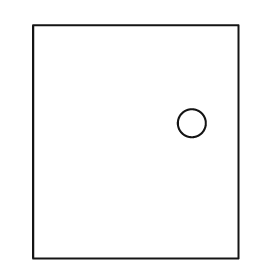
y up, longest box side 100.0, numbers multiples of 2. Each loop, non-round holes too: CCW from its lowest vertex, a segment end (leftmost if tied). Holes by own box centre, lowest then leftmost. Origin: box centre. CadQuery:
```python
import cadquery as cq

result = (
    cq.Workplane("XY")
    .moveTo(-44.0, -50.0)
    .lineTo(44.0, -50.0)
    .lineTo(44.0, 50.0)
    .lineTo(-44.0, 50.0)
    .close()
    .moveTo(24.0, 8.0)
    .circle(6.0)
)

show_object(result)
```